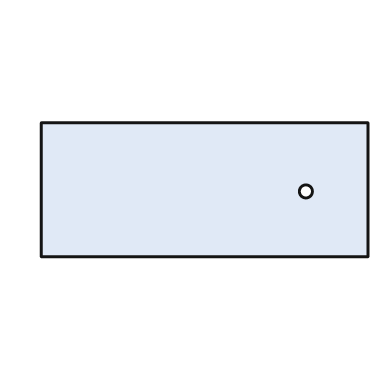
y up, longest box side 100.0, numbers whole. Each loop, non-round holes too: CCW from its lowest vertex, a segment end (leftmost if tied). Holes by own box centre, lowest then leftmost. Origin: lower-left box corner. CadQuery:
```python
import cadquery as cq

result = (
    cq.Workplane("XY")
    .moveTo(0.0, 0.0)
    .lineTo(100.0, 0.0)
    .lineTo(100.0, 41.0)
    .lineTo(0.0, 41.0)
    .close()
    .moveTo(81.0, 20.0)
    .circle(2.0)
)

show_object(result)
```